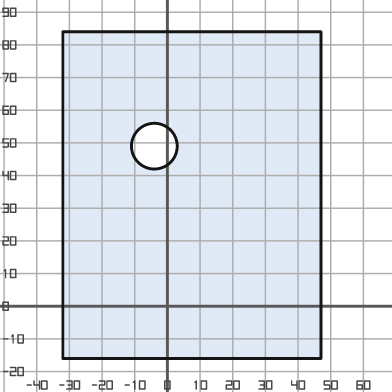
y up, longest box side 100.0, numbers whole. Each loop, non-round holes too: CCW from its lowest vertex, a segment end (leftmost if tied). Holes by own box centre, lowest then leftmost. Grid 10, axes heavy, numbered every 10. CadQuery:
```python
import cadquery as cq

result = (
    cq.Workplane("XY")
    .moveTo(-32.0, -16.0)
    .lineTo(47.0, -16.0)
    .lineTo(47.0, 84.0)
    .lineTo(-32.0, 84.0)
    .close()
    .moveTo(-4.0, 49.0)
    .circle(7.0)
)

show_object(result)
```